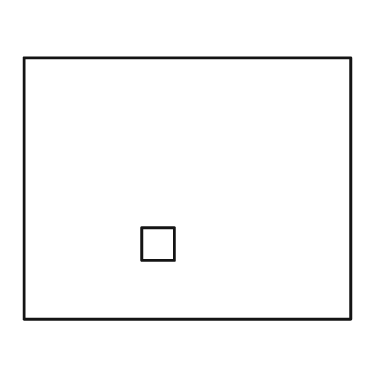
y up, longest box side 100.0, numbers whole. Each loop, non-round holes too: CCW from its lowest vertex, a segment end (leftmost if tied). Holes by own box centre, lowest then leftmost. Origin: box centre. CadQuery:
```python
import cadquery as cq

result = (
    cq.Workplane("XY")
    .moveTo(-50.0, -40.0)
    .lineTo(50.0, -40.0)
    .lineTo(50.0, 40.0)
    .lineTo(-50.0, 40.0)
    .close()
    .moveTo(-14.0, -22.0)
    .lineTo(-4.0, -22.0)
    .lineTo(-4.0, -12.0)
    .lineTo(-14.0, -12.0)
    .close()
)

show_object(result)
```